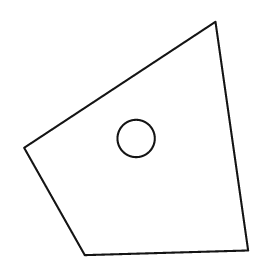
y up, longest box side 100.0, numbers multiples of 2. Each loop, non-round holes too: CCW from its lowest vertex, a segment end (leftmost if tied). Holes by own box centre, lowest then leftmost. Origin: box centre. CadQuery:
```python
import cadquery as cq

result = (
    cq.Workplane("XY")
    .moveTo(-22.0, -50.0)
    .lineTo(48.0, -48.0)
    .lineTo(34.0, 50.0)
    .lineTo(-48.0, -4.0)
    .close()
    .moveTo(0.0, 0.0)
    .circle(8.0)
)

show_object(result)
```